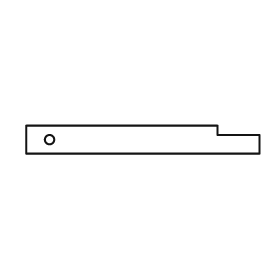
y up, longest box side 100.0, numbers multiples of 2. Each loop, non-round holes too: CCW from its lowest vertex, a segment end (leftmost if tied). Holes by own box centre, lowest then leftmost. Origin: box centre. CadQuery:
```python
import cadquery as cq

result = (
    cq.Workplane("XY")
    .moveTo(-50.0, -6.0)
    .lineTo(50.0, -6.0)
    .lineTo(50.0, 2.0)
    .lineTo(32.0, 2.0)
    .lineTo(32.0, 6.0)
    .lineTo(-50.0, 6.0)
    .close()
    .moveTo(-40.0, 0.0)
    .circle(2.0)
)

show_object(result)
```